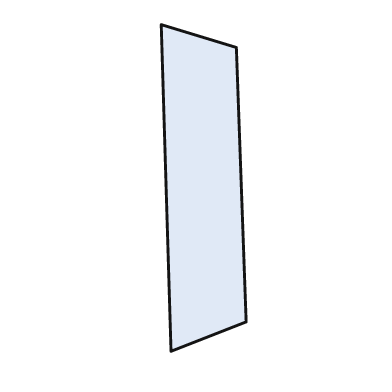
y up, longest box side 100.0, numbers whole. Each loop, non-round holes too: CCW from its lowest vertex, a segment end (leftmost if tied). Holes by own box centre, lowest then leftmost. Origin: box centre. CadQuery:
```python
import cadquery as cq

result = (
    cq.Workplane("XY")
    .moveTo(-10.0, -50.0)
    .lineTo(13.0, -41.0)
    .lineTo(10.0, 43.0)
    .lineTo(-13.0, 50.0)
    .close()
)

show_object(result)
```